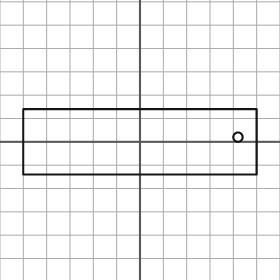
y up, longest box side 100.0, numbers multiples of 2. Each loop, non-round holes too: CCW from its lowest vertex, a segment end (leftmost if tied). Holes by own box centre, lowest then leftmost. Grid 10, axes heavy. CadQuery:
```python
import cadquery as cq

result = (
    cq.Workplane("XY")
    .moveTo(-50.0, -14.0)
    .lineTo(50.0, -14.0)
    .lineTo(50.0, 14.0)
    .lineTo(-50.0, 14.0)
    .close()
    .moveTo(42.0, 2.0)
    .circle(2.0)
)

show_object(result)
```